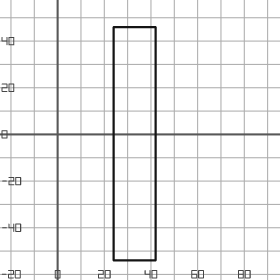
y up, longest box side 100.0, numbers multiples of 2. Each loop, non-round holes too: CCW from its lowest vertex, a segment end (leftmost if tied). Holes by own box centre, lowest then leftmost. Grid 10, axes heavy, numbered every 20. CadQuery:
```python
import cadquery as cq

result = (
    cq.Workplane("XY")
    .moveTo(24.0, -54.0)
    .lineTo(42.0, -54.0)
    .lineTo(42.0, 46.0)
    .lineTo(24.0, 46.0)
    .close()
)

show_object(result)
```